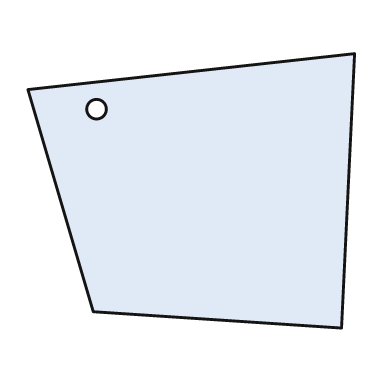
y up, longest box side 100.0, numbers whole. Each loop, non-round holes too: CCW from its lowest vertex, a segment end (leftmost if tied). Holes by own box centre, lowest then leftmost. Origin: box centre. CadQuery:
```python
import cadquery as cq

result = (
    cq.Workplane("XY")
    .moveTo(46.0, -42.0)
    .lineTo(50.0, 42.0)
    .lineTo(-50.0, 31.0)
    .lineTo(-30.0, -37.0)
    .close()
    .moveTo(-29.0, 25.0)
    .circle(3.0)
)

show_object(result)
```